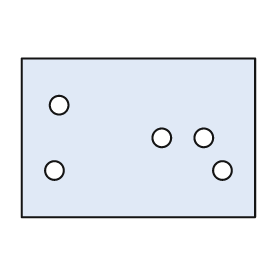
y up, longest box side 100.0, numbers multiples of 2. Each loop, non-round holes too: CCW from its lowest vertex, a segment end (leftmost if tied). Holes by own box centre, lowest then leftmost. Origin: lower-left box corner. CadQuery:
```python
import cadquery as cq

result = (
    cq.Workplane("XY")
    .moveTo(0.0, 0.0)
    .lineTo(100.0, 0.0)
    .lineTo(100.0, 68.0)
    .lineTo(0.0, 68.0)
    .close()
    .moveTo(14.0, 20.0)
    .circle(4.0)
    .moveTo(86.0, 20.0)
    .circle(4.0)
    .moveTo(60.0, 34.0)
    .circle(4.0)
    .moveTo(78.0, 34.0)
    .circle(4.0)
    .moveTo(16.0, 48.0)
    .circle(4.0)
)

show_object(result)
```